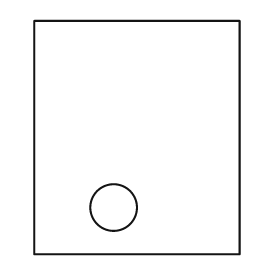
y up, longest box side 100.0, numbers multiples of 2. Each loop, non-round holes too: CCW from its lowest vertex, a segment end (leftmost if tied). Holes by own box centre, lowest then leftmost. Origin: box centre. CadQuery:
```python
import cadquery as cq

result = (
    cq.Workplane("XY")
    .moveTo(-44.0, -50.0)
    .lineTo(44.0, -50.0)
    .lineTo(44.0, 50.0)
    .lineTo(-44.0, 50.0)
    .close()
    .moveTo(-10.0, -30.0)
    .circle(10.0)
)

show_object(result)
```